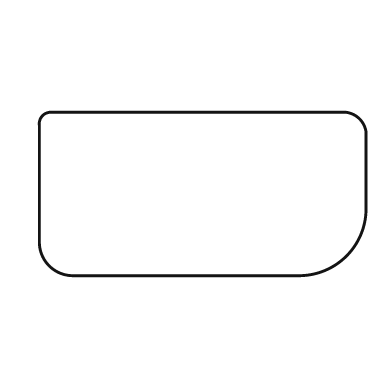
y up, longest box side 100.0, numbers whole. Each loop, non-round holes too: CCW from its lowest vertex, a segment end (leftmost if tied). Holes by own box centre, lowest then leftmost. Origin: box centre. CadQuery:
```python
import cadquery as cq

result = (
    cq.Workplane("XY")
    .moveTo(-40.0, -25.0)
    .lineTo(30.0, -25.0)
    .threePointArc((44.0, -19.0), (50.0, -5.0))
    .lineTo(50.0, 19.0)
    .threePointArc((48.0, 23.0), (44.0, 25.0))
    .lineTo(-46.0, 25.0)
    .threePointArc((-49.0, 24.0), (-50.0, 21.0))
    .lineTo(-50.0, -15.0)
    .threePointArc((-47.0, -22.0), (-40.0, -25.0))
    .close()
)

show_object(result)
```